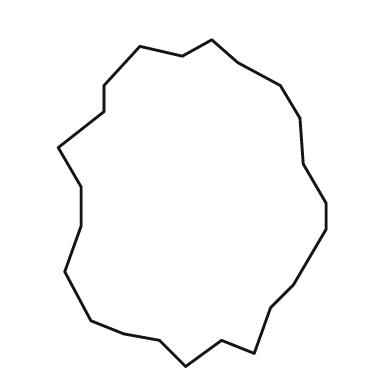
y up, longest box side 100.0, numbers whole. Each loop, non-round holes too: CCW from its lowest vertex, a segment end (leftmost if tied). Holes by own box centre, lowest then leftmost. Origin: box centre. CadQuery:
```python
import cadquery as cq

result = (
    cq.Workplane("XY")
    .moveTo(-2.0, -50.0)
    .lineTo(9.0, -42.0)
    .lineTo(19.0, -46.0)
    .lineTo(24.0, -32.0)
    .lineTo(31.0, -25.0)
    .lineTo(41.0, -8.0)
    .lineTo(41.0, 0.0)
    .lineTo(34.0, 12.0)
    .lineTo(33.0, 26.0)
    .lineTo(27.0, 36.0)
    .lineTo(14.0, 43.0)
    .lineTo(6.0, 50.0)
    .lineTo(-3.0, 45.0)
    .lineTo(-16.0, 48.0)
    .lineTo(-27.0, 36.0)
    .lineTo(-27.0, 28.0)
    .lineTo(-41.0, 17.0)
    .lineTo(-34.0, 5.0)
    .lineTo(-34.0, -7.0)
    .lineTo(-39.0, -21.0)
    .lineTo(-31.0, -36.0)
    .lineTo(-21.0, -40.0)
    .lineTo(-10.0, -42.0)
    .close()
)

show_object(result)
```